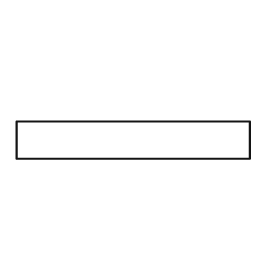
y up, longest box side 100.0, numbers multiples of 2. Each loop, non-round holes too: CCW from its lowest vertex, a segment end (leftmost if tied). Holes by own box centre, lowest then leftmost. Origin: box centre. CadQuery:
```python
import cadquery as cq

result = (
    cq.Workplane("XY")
    .moveTo(-50.0, -8.0)
    .lineTo(50.0, -8.0)
    .lineTo(50.0, 8.0)
    .lineTo(-50.0, 8.0)
    .close()
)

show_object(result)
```